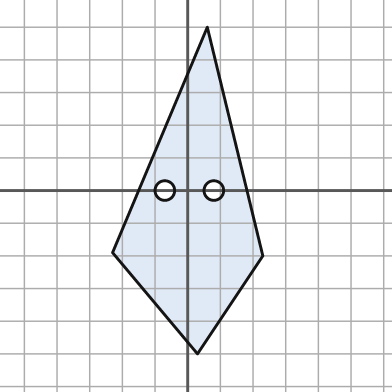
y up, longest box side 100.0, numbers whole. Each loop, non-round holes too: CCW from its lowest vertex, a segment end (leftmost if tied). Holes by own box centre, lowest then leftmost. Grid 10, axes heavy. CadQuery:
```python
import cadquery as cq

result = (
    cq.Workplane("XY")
    .moveTo(3.0, -50.0)
    .lineTo(23.0, -20.0)
    .lineTo(6.0, 50.0)
    .lineTo(-23.0, -19.0)
    .close()
    .moveTo(-7.0, 0.0)
    .circle(3.0)
    .moveTo(8.0, 0.0)
    .circle(3.0)
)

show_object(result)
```